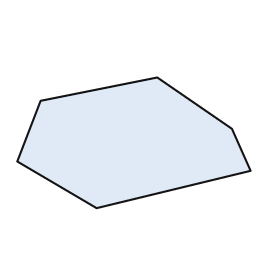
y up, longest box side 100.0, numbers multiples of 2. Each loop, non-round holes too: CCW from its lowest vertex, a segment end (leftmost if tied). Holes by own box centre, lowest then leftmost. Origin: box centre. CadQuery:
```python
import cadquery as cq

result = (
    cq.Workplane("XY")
    .moveTo(-16.0, -28.0)
    .lineTo(50.0, -12.0)
    .lineTo(42.0, 6.0)
    .lineTo(10.0, 28.0)
    .lineTo(-40.0, 18.0)
    .lineTo(-50.0, -8.0)
    .close()
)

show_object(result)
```